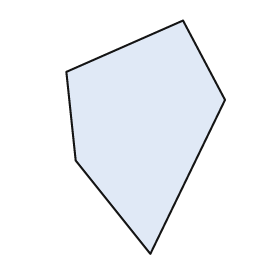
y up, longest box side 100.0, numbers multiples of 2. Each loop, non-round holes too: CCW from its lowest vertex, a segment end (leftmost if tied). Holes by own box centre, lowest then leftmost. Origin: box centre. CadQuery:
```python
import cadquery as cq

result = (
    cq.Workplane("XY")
    .moveTo(2.0, -50.0)
    .lineTo(34.0, 16.0)
    .lineTo(16.0, 50.0)
    .lineTo(-34.0, 28.0)
    .lineTo(-30.0, -10.0)
    .close()
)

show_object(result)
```